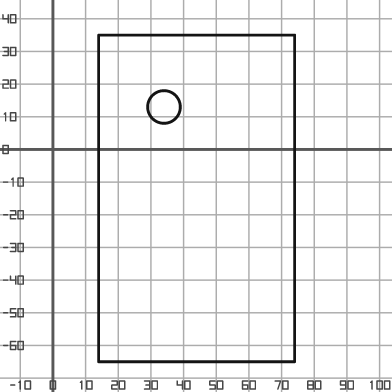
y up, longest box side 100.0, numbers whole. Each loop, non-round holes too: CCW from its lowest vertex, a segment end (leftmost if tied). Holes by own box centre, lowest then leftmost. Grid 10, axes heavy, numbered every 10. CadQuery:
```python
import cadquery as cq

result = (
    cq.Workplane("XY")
    .moveTo(14.0, -65.0)
    .lineTo(74.0, -65.0)
    .lineTo(74.0, 35.0)
    .lineTo(14.0, 35.0)
    .close()
    .moveTo(34.0, 13.0)
    .circle(5.0)
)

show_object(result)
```